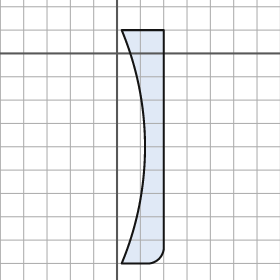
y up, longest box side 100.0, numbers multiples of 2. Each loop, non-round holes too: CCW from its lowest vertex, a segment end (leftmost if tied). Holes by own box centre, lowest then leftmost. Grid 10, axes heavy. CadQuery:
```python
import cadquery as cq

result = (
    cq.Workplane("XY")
    .moveTo(2.0, -90.0)
    .lineTo(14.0, -90.0)
    .threePointArc((18.0, -88.0), (20.0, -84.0))
    .lineTo(20.0, 10.0)
    .lineTo(2.0, 10.0)
    .threePointArc((12.0, -40.0), (2.0, -90.0))
    .close()
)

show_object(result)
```